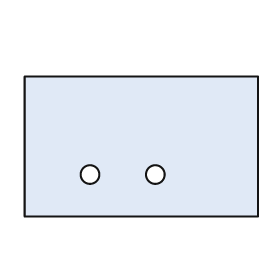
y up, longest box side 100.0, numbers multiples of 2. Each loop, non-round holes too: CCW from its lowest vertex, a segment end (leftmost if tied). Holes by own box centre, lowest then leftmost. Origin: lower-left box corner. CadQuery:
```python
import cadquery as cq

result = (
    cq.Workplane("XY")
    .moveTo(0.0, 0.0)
    .lineTo(100.0, 0.0)
    .lineTo(100.0, 60.0)
    .lineTo(0.0, 60.0)
    .close()
    .moveTo(28.0, 18.0)
    .circle(4.0)
    .moveTo(56.0, 18.0)
    .circle(4.0)
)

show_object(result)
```